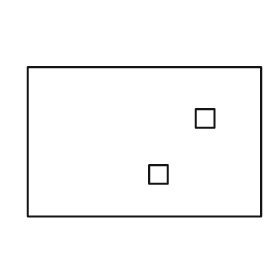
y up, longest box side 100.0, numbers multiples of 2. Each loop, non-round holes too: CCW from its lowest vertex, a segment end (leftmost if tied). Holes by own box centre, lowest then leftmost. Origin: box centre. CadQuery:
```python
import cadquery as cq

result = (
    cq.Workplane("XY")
    .moveTo(-50.0, -32.0)
    .lineTo(50.0, -32.0)
    .lineTo(50.0, 32.0)
    .lineTo(-50.0, 32.0)
    .close()
    .moveTo(2.0, -18.0)
    .lineTo(10.0, -18.0)
    .lineTo(10.0, -10.0)
    .lineTo(2.0, -10.0)
    .close()
    .moveTo(22.0, 6.0)
    .lineTo(30.0, 6.0)
    .lineTo(30.0, 14.0)
    .lineTo(22.0, 14.0)
    .close()
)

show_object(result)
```